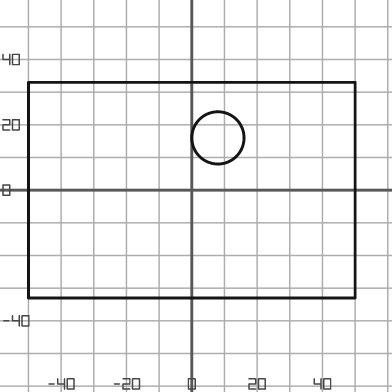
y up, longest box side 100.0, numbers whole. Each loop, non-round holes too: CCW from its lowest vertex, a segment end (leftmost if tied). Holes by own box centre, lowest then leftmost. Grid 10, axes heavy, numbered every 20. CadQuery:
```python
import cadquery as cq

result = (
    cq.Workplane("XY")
    .moveTo(-50.0, -33.0)
    .lineTo(50.0, -33.0)
    .lineTo(50.0, 33.0)
    .lineTo(-50.0, 33.0)
    .close()
    .moveTo(8.0, 16.0)
    .circle(8.0)
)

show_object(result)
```